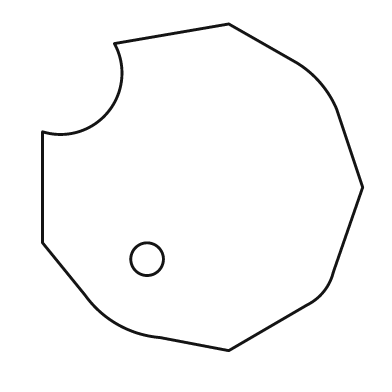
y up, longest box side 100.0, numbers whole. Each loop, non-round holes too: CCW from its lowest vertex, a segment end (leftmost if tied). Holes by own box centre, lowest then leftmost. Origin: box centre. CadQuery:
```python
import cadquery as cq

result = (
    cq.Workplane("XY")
    .moveTo(8.0, -50.0)
    .lineTo(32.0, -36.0)
    .threePointArc((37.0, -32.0), (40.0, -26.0))
    .lineTo(49.0, 0.0)
    .lineTo(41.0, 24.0)
    .threePointArc((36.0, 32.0), (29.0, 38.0))
    .lineTo(8.0, 50.0)
    .lineTo(-27.0, 44.0)
    .threePointArc((-29.0, 23.0), (-49.0, 17.0))
    .lineTo(-49.0, -17.0)
    .lineTo(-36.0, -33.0)
    .threePointArc((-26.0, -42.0), (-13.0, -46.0))
    .close()
    .moveTo(-17.0, -22.0)
    .circle(5.0)
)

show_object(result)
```